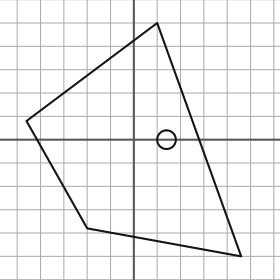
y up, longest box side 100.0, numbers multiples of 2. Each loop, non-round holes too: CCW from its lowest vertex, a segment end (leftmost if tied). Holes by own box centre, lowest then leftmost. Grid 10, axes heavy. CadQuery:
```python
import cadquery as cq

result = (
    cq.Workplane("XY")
    .moveTo(46.0, -50.0)
    .lineTo(10.0, 50.0)
    .lineTo(-46.0, 8.0)
    .lineTo(-20.0, -38.0)
    .close()
    .moveTo(14.0, 0.0)
    .circle(4.0)
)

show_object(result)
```